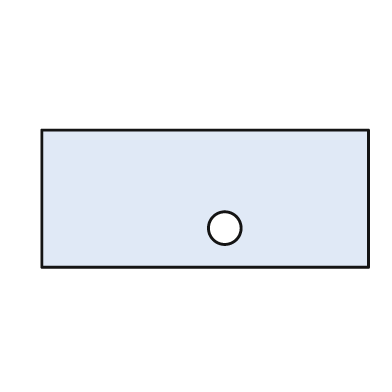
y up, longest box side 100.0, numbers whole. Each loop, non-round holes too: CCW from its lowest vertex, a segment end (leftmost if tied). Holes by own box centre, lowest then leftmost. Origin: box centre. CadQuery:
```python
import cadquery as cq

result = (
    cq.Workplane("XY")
    .moveTo(-50.0, -21.0)
    .lineTo(50.0, -21.0)
    .lineTo(50.0, 21.0)
    .lineTo(-50.0, 21.0)
    .close()
    .moveTo(6.0, -9.0)
    .circle(5.0)
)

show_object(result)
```